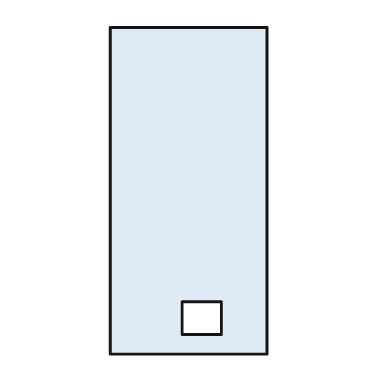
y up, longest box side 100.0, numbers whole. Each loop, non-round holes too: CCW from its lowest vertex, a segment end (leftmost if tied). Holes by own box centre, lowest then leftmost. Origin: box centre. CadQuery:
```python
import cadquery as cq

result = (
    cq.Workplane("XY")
    .moveTo(-24.0, -50.0)
    .lineTo(24.0, -50.0)
    .lineTo(24.0, 50.0)
    .lineTo(-24.0, 50.0)
    .close()
    .moveTo(-2.0, -44.0)
    .lineTo(10.0, -44.0)
    .lineTo(10.0, -34.0)
    .lineTo(-2.0, -34.0)
    .close()
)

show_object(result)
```